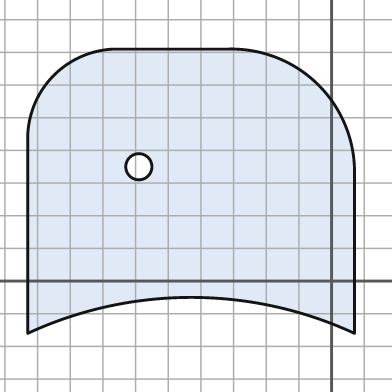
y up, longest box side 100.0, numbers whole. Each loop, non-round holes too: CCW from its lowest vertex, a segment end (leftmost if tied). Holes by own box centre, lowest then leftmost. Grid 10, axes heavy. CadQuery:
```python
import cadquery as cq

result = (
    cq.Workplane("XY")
    .moveTo(-93.0, -16.0)
    .threePointArc((-43.0, -5.0), (7.0, -16.0))
    .lineTo(7.0, 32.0)
    .threePointArc((-4.0, 60.0), (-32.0, 71.0))
    .lineTo(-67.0, 71.0)
    .threePointArc((-85.0, 63.0), (-93.0, 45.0))
    .close()
    .moveTo(-59.0, 35.0)
    .circle(4.0)
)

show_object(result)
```